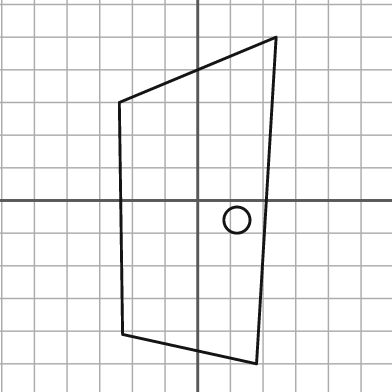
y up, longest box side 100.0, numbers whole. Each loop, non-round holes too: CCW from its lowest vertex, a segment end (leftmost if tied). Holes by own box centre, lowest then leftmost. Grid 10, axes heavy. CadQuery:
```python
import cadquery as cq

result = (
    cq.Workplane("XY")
    .moveTo(18.0, -50.0)
    .lineTo(24.0, 50.0)
    .lineTo(-24.0, 30.0)
    .lineTo(-23.0, -41.0)
    .close()
    .moveTo(12.0, -6.0)
    .circle(4.0)
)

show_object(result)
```